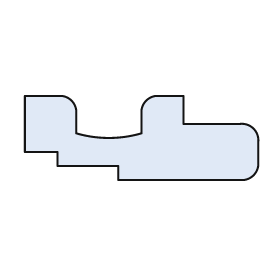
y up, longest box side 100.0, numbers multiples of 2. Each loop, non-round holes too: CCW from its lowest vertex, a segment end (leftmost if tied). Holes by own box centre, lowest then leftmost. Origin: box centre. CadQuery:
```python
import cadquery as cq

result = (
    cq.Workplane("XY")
    .moveTo(-10.0, -18.0)
    .lineTo(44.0, -18.0)
    .threePointArc((48.0, -16.0), (50.0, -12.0))
    .lineTo(50.0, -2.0)
    .threePointArc((48.0, 4.0), (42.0, 6.0))
    .lineTo(18.0, 6.0)
    .lineTo(18.0, 18.0)
    .lineTo(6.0, 18.0)
    .threePointArc((2.0, 16.0), (0.0, 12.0))
    .lineTo(0.0, 2.0)
    .threePointArc((-14.0, 0.0), (-28.0, 2.0))
    .lineTo(-28.0, 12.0)
    .threePointArc((-30.0, 16.0), (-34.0, 18.0))
    .lineTo(-50.0, 18.0)
    .lineTo(-50.0, -6.0)
    .lineTo(-36.0, -6.0)
    .lineTo(-36.0, -12.0)
    .lineTo(-10.0, -12.0)
    .close()
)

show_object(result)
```